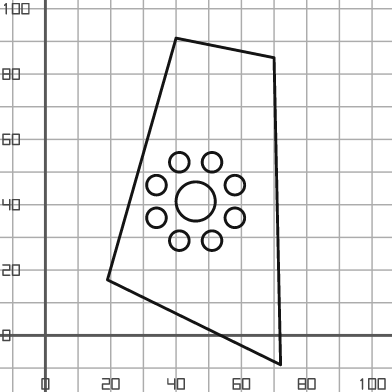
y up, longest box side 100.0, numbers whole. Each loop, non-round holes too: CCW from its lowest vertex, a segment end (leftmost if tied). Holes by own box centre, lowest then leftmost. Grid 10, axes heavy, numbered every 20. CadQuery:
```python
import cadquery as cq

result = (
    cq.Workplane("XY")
    .moveTo(72.0, -9.0)
    .lineTo(70.0, 85.0)
    .lineTo(40.0, 91.0)
    .lineTo(19.0, 17.0)
    .close()
    .moveTo(41.0, 29.0)
    .circle(3.0)
    .moveTo(51.0, 29.0)
    .circle(3.0)
    .moveTo(34.0, 36.0)
    .circle(3.0)
    .moveTo(58.0, 36.0)
    .circle(3.0)
    .moveTo(46.0, 41.0)
    .circle(6.0)
    .moveTo(34.0, 46.0)
    .circle(3.0)
    .moveTo(58.0, 46.0)
    .circle(3.0)
    .moveTo(41.0, 53.0)
    .circle(3.0)
    .moveTo(51.0, 53.0)
    .circle(3.0)
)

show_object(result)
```